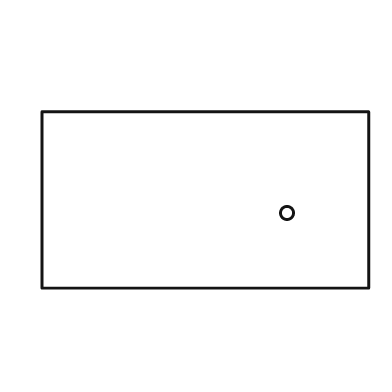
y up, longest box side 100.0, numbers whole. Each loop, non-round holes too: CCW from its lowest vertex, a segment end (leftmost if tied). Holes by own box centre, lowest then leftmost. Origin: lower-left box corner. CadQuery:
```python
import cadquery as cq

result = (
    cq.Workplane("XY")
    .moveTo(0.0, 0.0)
    .lineTo(100.0, 0.0)
    .lineTo(100.0, 54.0)
    .lineTo(0.0, 54.0)
    .close()
    .moveTo(75.0, 23.0)
    .circle(2.0)
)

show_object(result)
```